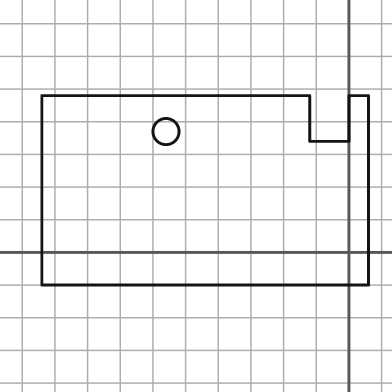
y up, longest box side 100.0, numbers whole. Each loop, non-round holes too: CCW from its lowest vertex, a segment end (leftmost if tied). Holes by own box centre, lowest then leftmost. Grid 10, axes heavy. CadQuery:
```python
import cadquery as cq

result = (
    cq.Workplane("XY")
    .moveTo(-94.0, -10.0)
    .lineTo(6.0, -10.0)
    .lineTo(6.0, 48.0)
    .lineTo(0.0, 48.0)
    .lineTo(0.0, 34.0)
    .lineTo(-12.0, 34.0)
    .lineTo(-12.0, 48.0)
    .lineTo(-94.0, 48.0)
    .close()
    .moveTo(-56.0, 37.0)
    .circle(4.0)
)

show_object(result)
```